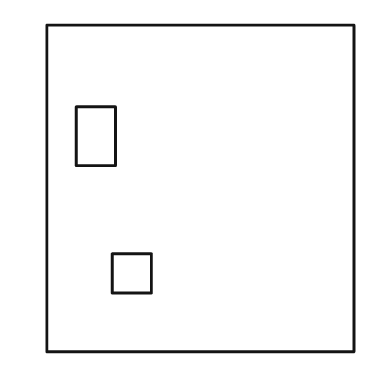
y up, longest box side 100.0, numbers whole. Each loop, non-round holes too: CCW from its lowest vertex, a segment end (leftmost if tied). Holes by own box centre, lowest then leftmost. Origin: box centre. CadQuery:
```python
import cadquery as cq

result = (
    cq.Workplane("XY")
    .moveTo(-47.0, -50.0)
    .lineTo(47.0, -50.0)
    .lineTo(47.0, 50.0)
    .lineTo(-47.0, 50.0)
    .close()
    .moveTo(-27.0, -32.0)
    .lineTo(-15.0, -32.0)
    .lineTo(-15.0, -20.0)
    .lineTo(-27.0, -20.0)
    .close()
    .moveTo(-38.0, 7.0)
    .lineTo(-26.0, 7.0)
    .lineTo(-26.0, 25.0)
    .lineTo(-38.0, 25.0)
    .close()
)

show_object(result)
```